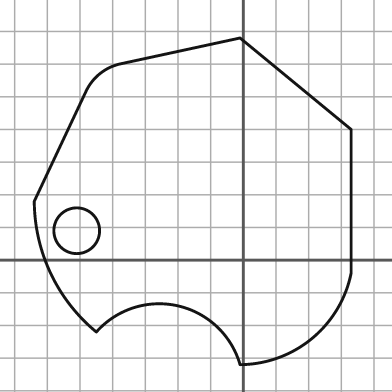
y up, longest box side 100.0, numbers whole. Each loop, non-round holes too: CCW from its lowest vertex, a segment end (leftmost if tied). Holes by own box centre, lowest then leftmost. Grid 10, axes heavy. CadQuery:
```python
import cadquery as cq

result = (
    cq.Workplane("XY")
    .moveTo(-1.0, -32.0)
    .threePointArc((21.0, -24.0), (33.0, -4.0))
    .lineTo(33.0, 40.0)
    .lineTo(-1.0, 68.0)
    .lineTo(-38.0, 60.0)
    .threePointArc((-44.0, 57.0), (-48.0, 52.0))
    .lineTo(-64.0, 18.0)
    .threePointArc((-59.0, -4.0), (-45.0, -22.0))
    .threePointArc((-20.0, -14.0), (-1.0, -32.0))
    .close()
    .moveTo(-51.0, 9.0)
    .circle(7.0)
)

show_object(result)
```